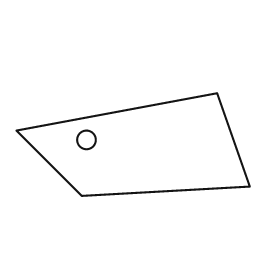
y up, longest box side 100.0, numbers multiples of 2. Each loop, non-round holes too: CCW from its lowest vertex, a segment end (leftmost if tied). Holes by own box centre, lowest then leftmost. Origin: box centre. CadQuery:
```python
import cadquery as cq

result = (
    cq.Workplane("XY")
    .moveTo(-22.0, -22.0)
    .lineTo(50.0, -18.0)
    .lineTo(36.0, 22.0)
    .lineTo(-50.0, 6.0)
    .close()
    .moveTo(-20.0, 2.0)
    .circle(4.0)
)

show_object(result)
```